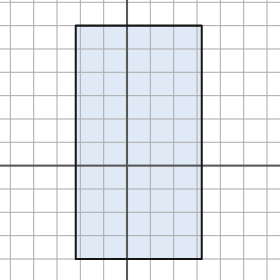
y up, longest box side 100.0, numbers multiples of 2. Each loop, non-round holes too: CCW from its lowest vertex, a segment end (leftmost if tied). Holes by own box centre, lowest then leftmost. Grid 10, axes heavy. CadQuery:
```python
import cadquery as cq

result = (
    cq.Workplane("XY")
    .moveTo(-22.0, -40.0)
    .lineTo(32.0, -40.0)
    .lineTo(32.0, 60.0)
    .lineTo(-22.0, 60.0)
    .close()
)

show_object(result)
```